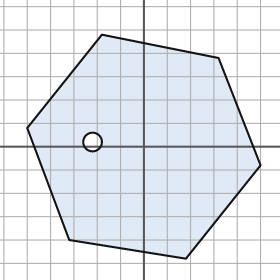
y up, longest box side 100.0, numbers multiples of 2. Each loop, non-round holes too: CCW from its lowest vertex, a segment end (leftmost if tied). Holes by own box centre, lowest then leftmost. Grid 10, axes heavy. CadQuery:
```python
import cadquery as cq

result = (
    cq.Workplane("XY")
    .moveTo(18.0, -48.0)
    .lineTo(50.0, -8.0)
    .lineTo(32.0, 38.0)
    .lineTo(-18.0, 48.0)
    .lineTo(-50.0, 8.0)
    .lineTo(-32.0, -40.0)
    .close()
    .moveTo(-22.0, 2.0)
    .circle(4.0)
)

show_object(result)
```